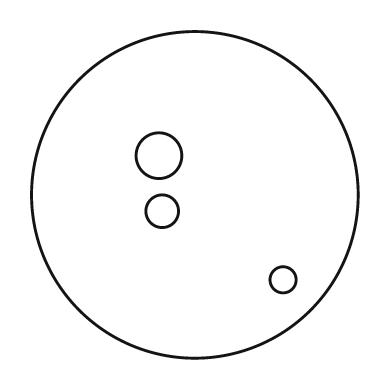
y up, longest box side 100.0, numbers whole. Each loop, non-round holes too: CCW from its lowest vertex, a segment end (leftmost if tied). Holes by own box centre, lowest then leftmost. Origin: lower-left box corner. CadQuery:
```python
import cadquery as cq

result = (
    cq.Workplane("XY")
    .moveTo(50.0, 50.0)
    .circle(50.0)
    .moveTo(77.0, 24.0)
    .circle(4.0)
    .moveTo(40.0, 45.0)
    .circle(5.0)
    .moveTo(39.0, 62.0)
    .circle(7.0)
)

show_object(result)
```